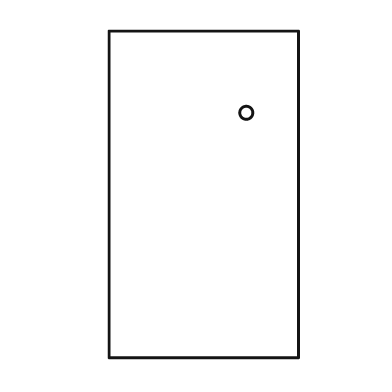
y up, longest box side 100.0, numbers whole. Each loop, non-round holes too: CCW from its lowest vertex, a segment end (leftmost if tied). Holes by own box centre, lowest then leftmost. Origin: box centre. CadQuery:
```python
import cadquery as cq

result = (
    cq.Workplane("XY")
    .moveTo(-29.0, -50.0)
    .lineTo(29.0, -50.0)
    .lineTo(29.0, 50.0)
    .lineTo(-29.0, 50.0)
    .close()
    .moveTo(13.0, 25.0)
    .circle(2.0)
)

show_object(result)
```